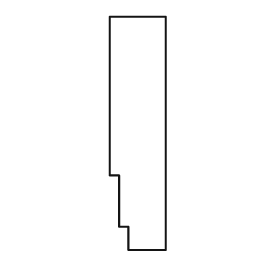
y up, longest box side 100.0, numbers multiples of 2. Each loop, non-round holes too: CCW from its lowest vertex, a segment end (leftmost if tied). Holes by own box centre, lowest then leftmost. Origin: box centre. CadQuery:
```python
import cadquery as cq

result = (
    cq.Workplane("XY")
    .moveTo(-4.0, -50.0)
    .lineTo(12.0, -50.0)
    .lineTo(12.0, 50.0)
    .lineTo(-12.0, 50.0)
    .lineTo(-12.0, -18.0)
    .lineTo(-8.0, -18.0)
    .lineTo(-8.0, -40.0)
    .lineTo(-4.0, -40.0)
    .close()
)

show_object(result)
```